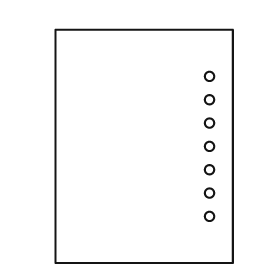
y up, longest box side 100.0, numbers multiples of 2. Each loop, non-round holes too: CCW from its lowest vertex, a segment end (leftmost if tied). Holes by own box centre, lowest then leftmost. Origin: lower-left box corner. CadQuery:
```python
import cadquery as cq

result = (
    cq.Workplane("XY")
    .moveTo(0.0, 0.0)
    .lineTo(76.0, 0.0)
    .lineTo(76.0, 100.0)
    .lineTo(0.0, 100.0)
    .close()
    .moveTo(66.0, 20.0)
    .circle(2.0)
    .moveTo(66.0, 30.0)
    .circle(2.0)
    .moveTo(66.0, 40.0)
    .circle(2.0)
    .moveTo(66.0, 50.0)
    .circle(2.0)
    .moveTo(66.0, 60.0)
    .circle(2.0)
    .moveTo(66.0, 70.0)
    .circle(2.0)
    .moveTo(66.0, 80.0)
    .circle(2.0)
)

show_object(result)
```